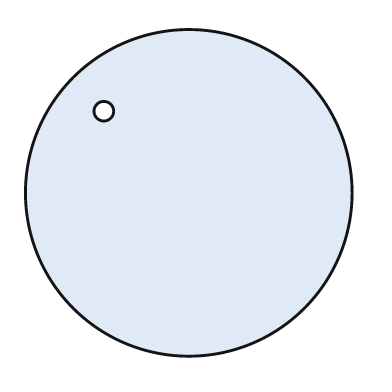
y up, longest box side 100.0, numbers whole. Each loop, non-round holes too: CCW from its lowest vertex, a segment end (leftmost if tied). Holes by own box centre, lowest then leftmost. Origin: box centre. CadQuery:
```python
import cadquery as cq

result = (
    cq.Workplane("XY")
    .moveTo(0.0, 0.0)
    .circle(50.0)
    .moveTo(-26.0, 25.0)
    .circle(3.0)
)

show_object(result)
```